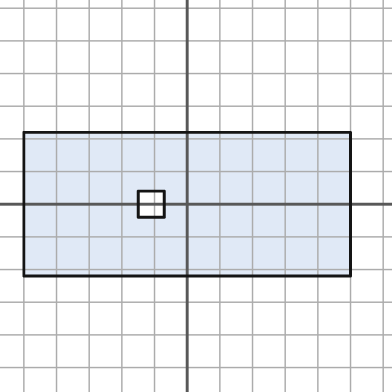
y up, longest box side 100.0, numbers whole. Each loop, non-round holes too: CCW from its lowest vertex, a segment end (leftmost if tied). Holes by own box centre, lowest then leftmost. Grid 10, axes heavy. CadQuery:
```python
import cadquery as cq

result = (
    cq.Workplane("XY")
    .moveTo(-50.0, -22.0)
    .lineTo(50.0, -22.0)
    .lineTo(50.0, 22.0)
    .lineTo(-50.0, 22.0)
    .close()
    .moveTo(-15.0, -4.0)
    .lineTo(-7.0, -4.0)
    .lineTo(-7.0, 4.0)
    .lineTo(-15.0, 4.0)
    .close()
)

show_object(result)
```